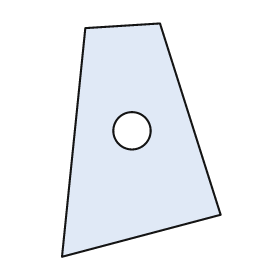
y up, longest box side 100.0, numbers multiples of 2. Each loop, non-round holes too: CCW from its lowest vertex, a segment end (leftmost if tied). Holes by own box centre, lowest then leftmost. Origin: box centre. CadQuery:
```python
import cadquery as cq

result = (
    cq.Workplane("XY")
    .moveTo(-34.0, -50.0)
    .lineTo(34.0, -32.0)
    .lineTo(8.0, 50.0)
    .lineTo(-24.0, 48.0)
    .close()
    .moveTo(-4.0, 4.0)
    .circle(8.0)
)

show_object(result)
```